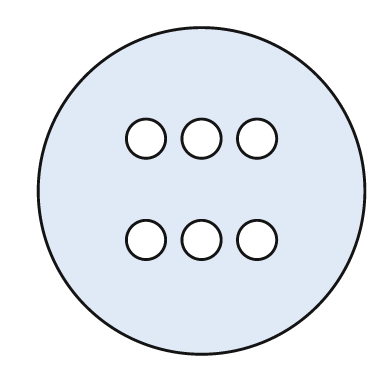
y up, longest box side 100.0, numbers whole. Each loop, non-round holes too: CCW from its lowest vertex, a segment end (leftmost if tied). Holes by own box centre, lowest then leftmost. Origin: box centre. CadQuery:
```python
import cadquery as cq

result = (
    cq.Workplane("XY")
    .moveTo(0.0, 0.0)
    .circle(50.0)
    .moveTo(-17.0, -15.0)
    .circle(6.0)
    .moveTo(0.0, -15.0)
    .circle(6.0)
    .moveTo(17.0, -15.0)
    .circle(6.0)
    .moveTo(-17.0, 16.0)
    .circle(6.0)
    .moveTo(0.0, 16.0)
    .circle(6.0)
    .moveTo(17.0, 16.0)
    .circle(6.0)
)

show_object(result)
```